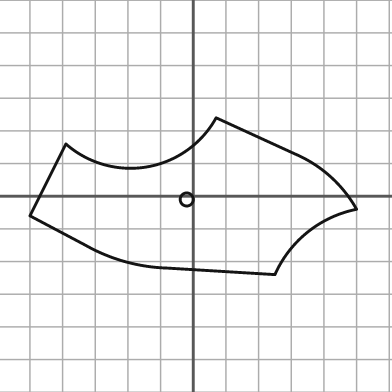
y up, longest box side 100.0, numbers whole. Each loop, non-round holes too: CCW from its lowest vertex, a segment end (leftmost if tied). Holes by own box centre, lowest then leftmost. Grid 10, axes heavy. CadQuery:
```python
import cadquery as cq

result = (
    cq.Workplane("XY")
    .moveTo(25.0, -24.0)
    .threePointArc((35.0, -11.0), (50.0, -4.0))
    .threePointArc((42.0, 6.0), (31.0, 13.0))
    .lineTo(7.0, 24.0)
    .threePointArc((-14.0, 9.0), (-39.0, 16.0))
    .lineTo(-50.0, -6.0)
    .lineTo(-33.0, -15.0)
    .threePointArc((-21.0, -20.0), (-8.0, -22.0))
    .close()
    .moveTo(-2.0, -1.0)
    .circle(2.0)
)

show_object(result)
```